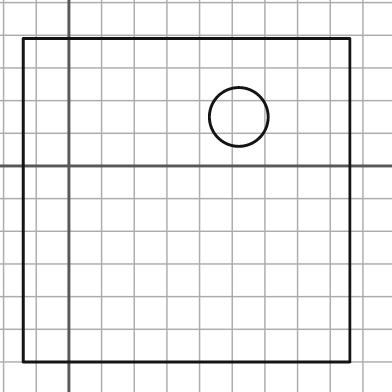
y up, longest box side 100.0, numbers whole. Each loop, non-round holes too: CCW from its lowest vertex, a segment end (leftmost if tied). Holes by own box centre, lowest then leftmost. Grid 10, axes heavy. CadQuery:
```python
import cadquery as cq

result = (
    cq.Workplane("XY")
    .moveTo(-14.0, -60.0)
    .lineTo(86.0, -60.0)
    .lineTo(86.0, 39.0)
    .lineTo(-14.0, 39.0)
    .close()
    .moveTo(52.0, 15.0)
    .circle(9.0)
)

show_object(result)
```